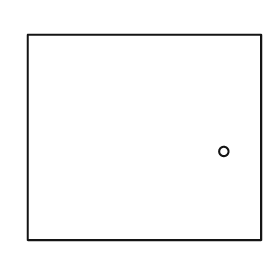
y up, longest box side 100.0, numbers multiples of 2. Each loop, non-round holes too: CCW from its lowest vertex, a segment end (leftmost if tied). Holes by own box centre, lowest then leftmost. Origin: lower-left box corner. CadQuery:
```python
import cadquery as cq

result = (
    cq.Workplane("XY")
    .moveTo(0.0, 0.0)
    .lineTo(100.0, 0.0)
    .lineTo(100.0, 88.0)
    .lineTo(0.0, 88.0)
    .close()
    .moveTo(84.0, 38.0)
    .circle(2.0)
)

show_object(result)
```